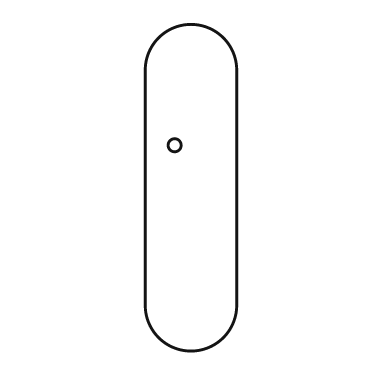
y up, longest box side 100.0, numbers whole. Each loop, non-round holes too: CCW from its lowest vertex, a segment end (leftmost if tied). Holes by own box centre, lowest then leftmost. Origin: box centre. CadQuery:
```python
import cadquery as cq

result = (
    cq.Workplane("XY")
    .moveTo(-14.0, -36.0)
    .threePointArc((0.0, -50.0), (14.0, -36.0))
    .lineTo(14.0, 36.0)
    .threePointArc((0.0, 50.0), (-14.0, 36.0))
    .close()
    .moveTo(-5.0, 13.0)
    .circle(2.0)
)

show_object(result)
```